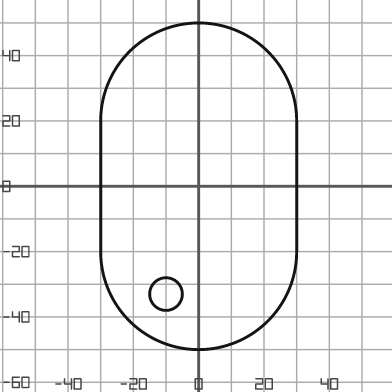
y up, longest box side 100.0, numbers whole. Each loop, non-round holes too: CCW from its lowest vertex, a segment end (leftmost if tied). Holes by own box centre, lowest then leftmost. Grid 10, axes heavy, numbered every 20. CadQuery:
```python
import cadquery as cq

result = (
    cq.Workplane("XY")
    .moveTo(-30.0, -20.0)
    .threePointArc((0.0, -50.0), (30.0, -20.0))
    .lineTo(30.0, 20.0)
    .threePointArc((0.0, 50.0), (-30.0, 20.0))
    .close()
    .moveTo(-10.0, -33.0)
    .circle(5.0)
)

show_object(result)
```